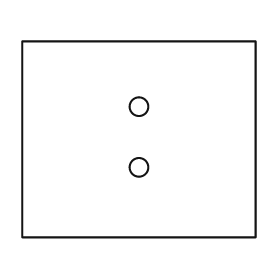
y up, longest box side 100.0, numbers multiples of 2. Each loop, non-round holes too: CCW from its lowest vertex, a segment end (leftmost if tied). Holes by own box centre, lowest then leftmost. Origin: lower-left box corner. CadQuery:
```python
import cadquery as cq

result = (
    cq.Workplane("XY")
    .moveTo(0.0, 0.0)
    .lineTo(100.0, 0.0)
    .lineTo(100.0, 84.0)
    .lineTo(0.0, 84.0)
    .close()
    .moveTo(50.0, 30.0)
    .circle(4.0)
    .moveTo(50.0, 56.0)
    .circle(4.0)
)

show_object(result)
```